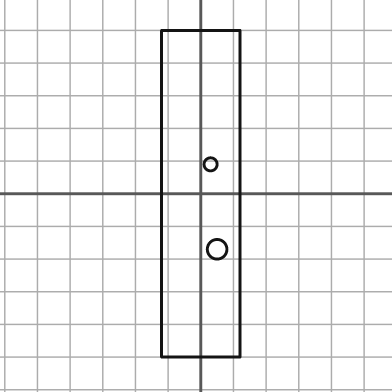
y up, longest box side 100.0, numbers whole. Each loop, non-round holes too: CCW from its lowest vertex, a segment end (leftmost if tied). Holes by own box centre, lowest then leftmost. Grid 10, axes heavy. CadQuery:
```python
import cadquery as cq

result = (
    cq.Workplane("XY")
    .moveTo(-12.0, -50.0)
    .lineTo(12.0, -50.0)
    .lineTo(12.0, 50.0)
    .lineTo(-12.0, 50.0)
    .close()
    .moveTo(5.0, -17.0)
    .circle(3.0)
    .moveTo(3.0, 9.0)
    .circle(2.0)
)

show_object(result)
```